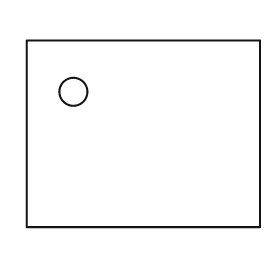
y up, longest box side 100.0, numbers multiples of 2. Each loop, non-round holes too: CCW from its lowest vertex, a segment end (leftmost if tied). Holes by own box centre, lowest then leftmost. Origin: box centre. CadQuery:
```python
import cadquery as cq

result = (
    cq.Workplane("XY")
    .moveTo(-50.0, -40.0)
    .lineTo(50.0, -40.0)
    .lineTo(50.0, 40.0)
    .lineTo(-50.0, 40.0)
    .close()
    .moveTo(-30.0, 18.0)
    .circle(6.0)
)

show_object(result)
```